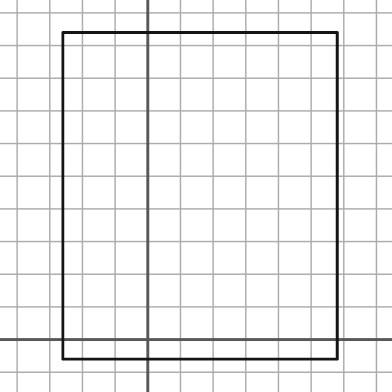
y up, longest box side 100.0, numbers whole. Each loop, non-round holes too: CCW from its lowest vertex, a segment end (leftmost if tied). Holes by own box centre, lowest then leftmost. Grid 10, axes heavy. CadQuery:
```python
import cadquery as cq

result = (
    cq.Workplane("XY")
    .moveTo(-26.0, -6.0)
    .lineTo(58.0, -6.0)
    .lineTo(58.0, 94.0)
    .lineTo(-26.0, 94.0)
    .close()
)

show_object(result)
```